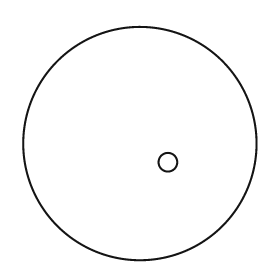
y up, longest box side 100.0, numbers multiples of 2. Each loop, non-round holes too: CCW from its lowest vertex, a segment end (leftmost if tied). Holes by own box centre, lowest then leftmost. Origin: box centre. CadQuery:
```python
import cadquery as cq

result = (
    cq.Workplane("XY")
    .moveTo(0.0, 0.0)
    .circle(50.0)
    .moveTo(12.0, -8.0)
    .circle(4.0)
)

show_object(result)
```